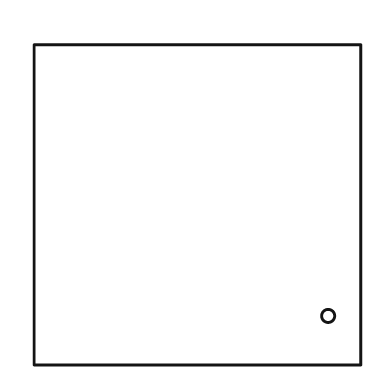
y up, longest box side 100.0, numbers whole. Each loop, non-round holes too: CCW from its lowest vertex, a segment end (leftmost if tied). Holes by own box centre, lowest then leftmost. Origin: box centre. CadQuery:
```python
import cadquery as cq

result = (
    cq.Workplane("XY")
    .moveTo(-50.0, -49.0)
    .lineTo(50.0, -49.0)
    .lineTo(50.0, 49.0)
    .lineTo(-50.0, 49.0)
    .close()
    .moveTo(40.0, -34.0)
    .circle(2.0)
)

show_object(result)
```